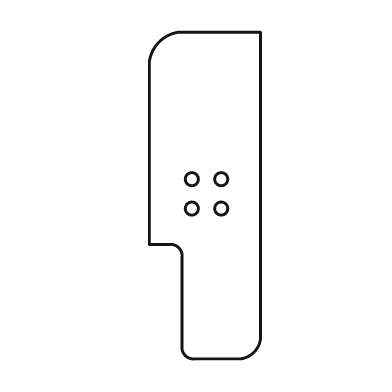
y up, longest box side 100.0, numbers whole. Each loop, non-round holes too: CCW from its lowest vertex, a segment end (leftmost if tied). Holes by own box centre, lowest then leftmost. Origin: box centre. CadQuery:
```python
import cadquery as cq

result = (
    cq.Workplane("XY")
    .moveTo(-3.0, -50.0)
    .lineTo(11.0, -50.0)
    .threePointArc((15.0, -48.0), (17.0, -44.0))
    .lineTo(17.0, 50.0)
    .lineTo(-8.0, 50.0)
    .threePointArc((-14.0, 47.0), (-17.0, 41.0))
    .lineTo(-17.0, -15.0)
    .lineTo(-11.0, -15.0)
    .threePointArc((-8.0, -16.0), (-7.0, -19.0))
    .lineTo(-7.0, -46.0)
    .threePointArc((-6.0, -49.0), (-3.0, -50.0))
    .close()
    .moveTo(-4.0, -4.0)
    .circle(2.0)
    .moveTo(5.0, -4.0)
    .circle(2.0)
    .moveTo(-4.0, 5.0)
    .circle(2.0)
    .moveTo(5.0, 5.0)
    .circle(2.0)
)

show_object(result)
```